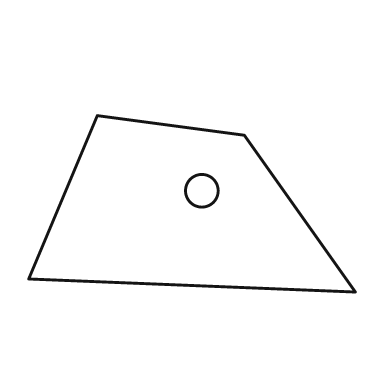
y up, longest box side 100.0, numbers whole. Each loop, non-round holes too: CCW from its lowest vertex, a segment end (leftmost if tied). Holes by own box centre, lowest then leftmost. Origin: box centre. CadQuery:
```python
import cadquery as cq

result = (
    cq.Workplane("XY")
    .moveTo(50.0, -27.0)
    .lineTo(16.0, 21.0)
    .lineTo(-29.0, 27.0)
    .lineTo(-50.0, -23.0)
    .close()
    .moveTo(3.0, 4.0)
    .circle(5.0)
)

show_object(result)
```